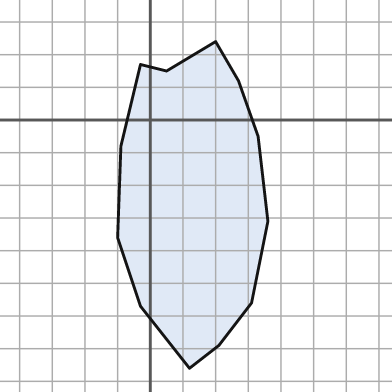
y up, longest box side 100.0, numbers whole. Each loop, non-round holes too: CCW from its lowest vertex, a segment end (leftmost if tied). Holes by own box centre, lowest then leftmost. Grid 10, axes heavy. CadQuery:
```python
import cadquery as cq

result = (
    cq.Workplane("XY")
    .moveTo(12.0, -76.0)
    .lineTo(21.0, -69.0)
    .lineTo(31.0, -56.0)
    .lineTo(36.0, -31.0)
    .lineTo(33.0, -5.0)
    .lineTo(27.0, 12.0)
    .lineTo(20.0, 24.0)
    .lineTo(5.0, 15.0)
    .lineTo(-3.0, 17.0)
    .lineTo(-9.0, -8.0)
    .lineTo(-10.0, -36.0)
    .lineTo(-3.0, -57.0)
    .close()
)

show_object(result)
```